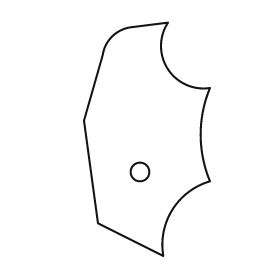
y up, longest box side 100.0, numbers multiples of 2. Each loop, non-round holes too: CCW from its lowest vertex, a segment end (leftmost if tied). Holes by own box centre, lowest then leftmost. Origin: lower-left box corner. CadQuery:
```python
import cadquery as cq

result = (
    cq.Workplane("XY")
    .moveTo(34.0, 0.0)
    .threePointArc((38.0, 20.0), (54.0, 32.0))
    .threePointArc((50.0, 52.0), (54.0, 72.0))
    .threePointArc((36.0, 80.0), (36.0, 100.0))
    .lineTo(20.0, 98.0)
    .threePointArc((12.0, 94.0), (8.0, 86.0))
    .lineTo(0.0, 58.0)
    .lineTo(6.0, 14.0)
    .close()
    .moveTo(24.0, 36.0)
    .circle(4.0)
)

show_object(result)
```